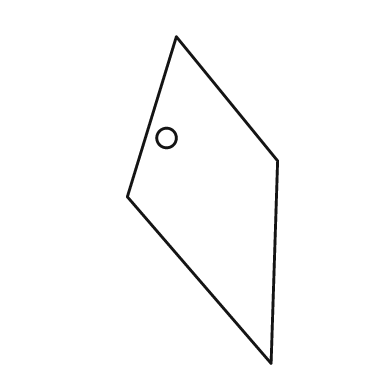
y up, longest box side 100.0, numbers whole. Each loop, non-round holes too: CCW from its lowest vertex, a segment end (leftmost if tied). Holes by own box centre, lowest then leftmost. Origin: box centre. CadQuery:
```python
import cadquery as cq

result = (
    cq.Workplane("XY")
    .moveTo(21.0, -50.0)
    .lineTo(23.0, 12.0)
    .lineTo(-8.0, 50.0)
    .lineTo(-23.0, 1.0)
    .close()
    .moveTo(-11.0, 19.0)
    .circle(3.0)
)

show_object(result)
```